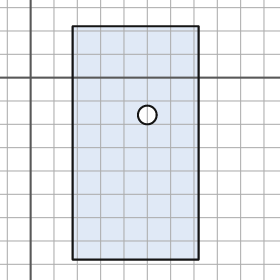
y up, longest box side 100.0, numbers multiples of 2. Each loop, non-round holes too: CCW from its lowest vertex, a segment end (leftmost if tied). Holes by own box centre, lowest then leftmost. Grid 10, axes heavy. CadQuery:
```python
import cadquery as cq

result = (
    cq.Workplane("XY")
    .moveTo(18.0, -78.0)
    .lineTo(72.0, -78.0)
    .lineTo(72.0, 22.0)
    .lineTo(18.0, 22.0)
    .close()
    .moveTo(50.0, -16.0)
    .circle(4.0)
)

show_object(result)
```